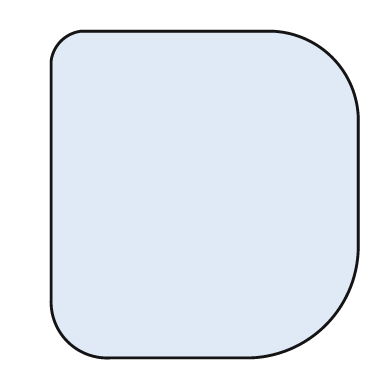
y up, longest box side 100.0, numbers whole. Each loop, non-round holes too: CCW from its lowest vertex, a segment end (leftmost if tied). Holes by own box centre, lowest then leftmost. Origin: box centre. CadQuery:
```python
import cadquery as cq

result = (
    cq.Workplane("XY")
    .moveTo(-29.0, -50.0)
    .lineTo(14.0, -50.0)
    .threePointArc((37.0, -40.0), (47.0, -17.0))
    .lineTo(47.0, 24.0)
    .threePointArc((39.0, 42.0), (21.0, 50.0))
    .lineTo(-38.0, 50.0)
    .threePointArc((-44.0, 47.0), (-47.0, 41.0))
    .lineTo(-47.0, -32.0)
    .threePointArc((-42.0, -45.0), (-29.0, -50.0))
    .close()
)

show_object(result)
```